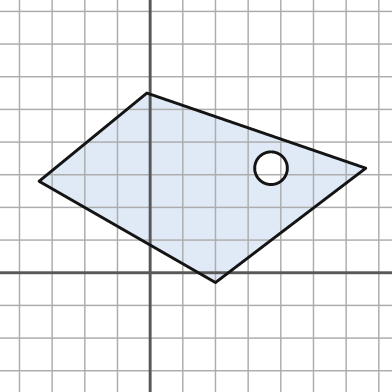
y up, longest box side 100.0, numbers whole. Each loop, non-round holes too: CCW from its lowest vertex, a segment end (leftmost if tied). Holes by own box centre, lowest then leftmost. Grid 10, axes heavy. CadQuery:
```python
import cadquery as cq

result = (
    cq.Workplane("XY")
    .moveTo(20.0, -3.0)
    .lineTo(66.0, 32.0)
    .lineTo(-1.0, 55.0)
    .lineTo(-34.0, 28.0)
    .close()
    .moveTo(37.0, 32.0)
    .circle(5.0)
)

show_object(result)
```